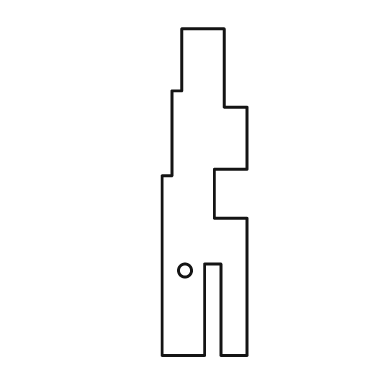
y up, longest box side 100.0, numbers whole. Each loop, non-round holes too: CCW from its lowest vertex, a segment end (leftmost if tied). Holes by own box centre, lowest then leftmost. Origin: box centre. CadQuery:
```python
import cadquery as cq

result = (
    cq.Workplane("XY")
    .moveTo(-13.0, -50.0)
    .lineTo(0.0, -50.0)
    .lineTo(0.0, -22.0)
    .lineTo(5.0, -22.0)
    .lineTo(5.0, -50.0)
    .lineTo(13.0, -50.0)
    .lineTo(13.0, -8.0)
    .lineTo(3.0, -8.0)
    .lineTo(3.0, 7.0)
    .lineTo(13.0, 7.0)
    .lineTo(13.0, 26.0)
    .lineTo(6.0, 26.0)
    .lineTo(6.0, 50.0)
    .lineTo(-7.0, 50.0)
    .lineTo(-7.0, 31.0)
    .lineTo(-10.0, 31.0)
    .lineTo(-10.0, 5.0)
    .lineTo(-13.0, 5.0)
    .close()
    .moveTo(-6.0, -24.0)
    .circle(2.0)
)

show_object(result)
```